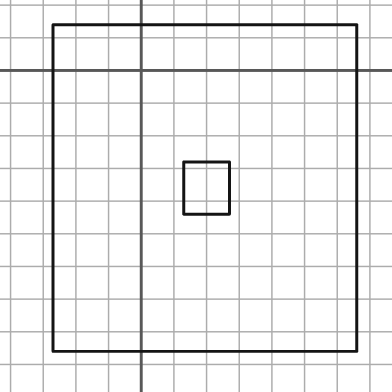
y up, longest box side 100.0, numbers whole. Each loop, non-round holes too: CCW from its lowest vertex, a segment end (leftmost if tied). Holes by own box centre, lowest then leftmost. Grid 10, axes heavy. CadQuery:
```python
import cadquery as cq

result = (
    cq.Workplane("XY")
    .moveTo(-27.0, -86.0)
    .lineTo(66.0, -86.0)
    .lineTo(66.0, 14.0)
    .lineTo(-27.0, 14.0)
    .close()
    .moveTo(13.0, -44.0)
    .lineTo(27.0, -44.0)
    .lineTo(27.0, -28.0)
    .lineTo(13.0, -28.0)
    .close()
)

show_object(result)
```